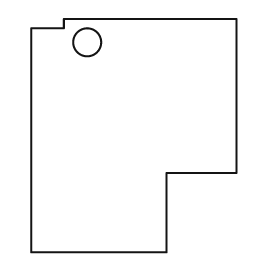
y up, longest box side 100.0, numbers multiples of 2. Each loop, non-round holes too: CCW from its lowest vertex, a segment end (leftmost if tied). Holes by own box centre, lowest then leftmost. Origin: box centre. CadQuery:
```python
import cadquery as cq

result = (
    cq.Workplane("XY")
    .moveTo(-44.0, -50.0)
    .lineTo(14.0, -50.0)
    .lineTo(14.0, -16.0)
    .lineTo(44.0, -16.0)
    .lineTo(44.0, 50.0)
    .lineTo(-30.0, 50.0)
    .lineTo(-30.0, 46.0)
    .lineTo(-44.0, 46.0)
    .close()
    .moveTo(-20.0, 40.0)
    .circle(6.0)
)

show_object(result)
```